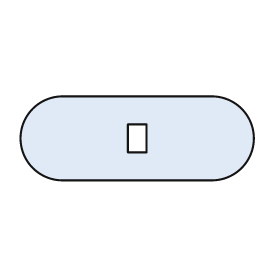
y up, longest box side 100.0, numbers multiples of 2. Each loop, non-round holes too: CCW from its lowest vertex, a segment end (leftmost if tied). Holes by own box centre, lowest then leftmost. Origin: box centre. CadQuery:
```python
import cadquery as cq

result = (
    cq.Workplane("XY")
    .moveTo(-32.0, -18.0)
    .lineTo(32.0, -18.0)
    .threePointArc((50.0, 0.0), (32.0, 18.0))
    .lineTo(-32.0, 18.0)
    .threePointArc((-50.0, 0.0), (-32.0, -18.0))
    .close()
    .moveTo(-4.0, -6.0)
    .lineTo(4.0, -6.0)
    .lineTo(4.0, 6.0)
    .lineTo(-4.0, 6.0)
    .close()
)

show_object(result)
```